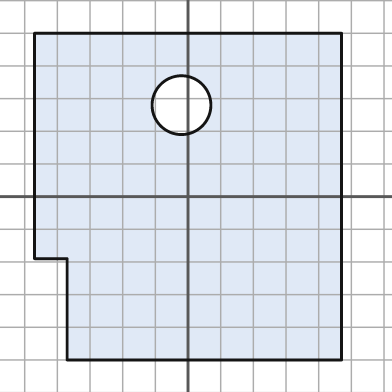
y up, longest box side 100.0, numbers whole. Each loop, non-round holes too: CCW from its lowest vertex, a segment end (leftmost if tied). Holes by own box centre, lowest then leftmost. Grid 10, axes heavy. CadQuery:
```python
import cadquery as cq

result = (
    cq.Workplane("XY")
    .moveTo(-37.0, -50.0)
    .lineTo(47.0, -50.0)
    .lineTo(47.0, 50.0)
    .lineTo(-47.0, 50.0)
    .lineTo(-47.0, -19.0)
    .lineTo(-37.0, -19.0)
    .close()
    .moveTo(-2.0, 28.0)
    .circle(9.0)
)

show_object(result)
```